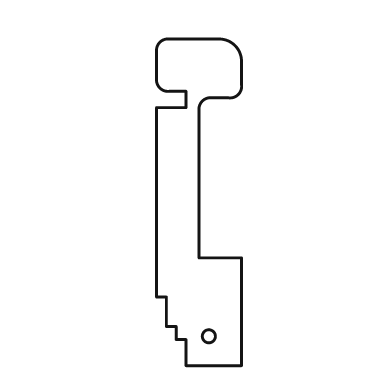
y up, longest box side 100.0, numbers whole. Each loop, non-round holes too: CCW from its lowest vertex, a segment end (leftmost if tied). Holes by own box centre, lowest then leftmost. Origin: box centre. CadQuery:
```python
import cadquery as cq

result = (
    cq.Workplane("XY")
    .moveTo(-4.0, -50.0)
    .lineTo(13.0, -50.0)
    .lineTo(13.0, -17.0)
    .lineTo(0.0, -17.0)
    .lineTo(0.0, 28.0)
    .threePointArc((1.0, 31.0), (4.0, 32.0))
    .lineTo(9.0, 32.0)
    .threePointArc((12.0, 33.0), (13.0, 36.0))
    .lineTo(13.0, 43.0)
    .threePointArc((11.0, 48.0), (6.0, 50.0))
    .lineTo(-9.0, 50.0)
    .threePointArc((-12.0, 49.0), (-13.0, 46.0))
    .lineTo(-13.0, 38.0)
    .threePointArc((-12.0, 35.0), (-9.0, 34.0))
    .lineTo(-4.0, 34.0)
    .lineTo(-4.0, 29.0)
    .lineTo(-13.0, 29.0)
    .lineTo(-13.0, -29.0)
    .lineTo(-10.0, -29.0)
    .lineTo(-10.0, -38.0)
    .lineTo(-7.0, -38.0)
    .lineTo(-7.0, -42.0)
    .lineTo(-4.0, -42.0)
    .close()
    .moveTo(3.0, -41.0)
    .circle(2.0)
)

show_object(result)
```